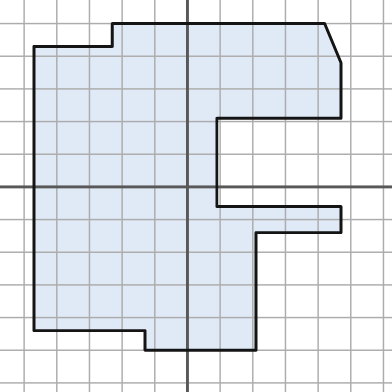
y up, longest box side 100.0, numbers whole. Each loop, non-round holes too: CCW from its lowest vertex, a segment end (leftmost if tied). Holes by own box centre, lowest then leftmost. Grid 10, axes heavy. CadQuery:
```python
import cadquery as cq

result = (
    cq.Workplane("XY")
    .moveTo(-13.0, -50.0)
    .lineTo(21.0, -50.0)
    .lineTo(21.0, -14.0)
    .lineTo(47.0, -14.0)
    .lineTo(47.0, -6.0)
    .lineTo(9.0, -6.0)
    .lineTo(9.0, 21.0)
    .lineTo(47.0, 21.0)
    .lineTo(47.0, 38.0)
    .lineTo(42.0, 50.0)
    .lineTo(-23.0, 50.0)
    .lineTo(-23.0, 43.0)
    .lineTo(-47.0, 43.0)
    .lineTo(-47.0, -44.0)
    .lineTo(-13.0, -44.0)
    .close()
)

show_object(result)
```